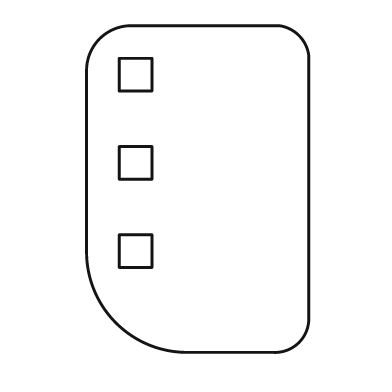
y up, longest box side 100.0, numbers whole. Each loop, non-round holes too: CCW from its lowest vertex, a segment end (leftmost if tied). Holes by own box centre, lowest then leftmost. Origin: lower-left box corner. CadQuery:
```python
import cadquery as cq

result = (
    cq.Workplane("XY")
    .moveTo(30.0, 0.0)
    .lineTo(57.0, 0.0)
    .threePointArc((65.0, 3.0), (68.0, 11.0))
    .lineTo(68.0, 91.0)
    .threePointArc((65.0, 97.0), (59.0, 100.0))
    .lineTo(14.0, 100.0)
    .threePointArc((4.0, 96.0), (0.0, 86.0))
    .lineTo(0.0, 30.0)
    .threePointArc((9.0, 9.0), (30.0, 0.0))
    .close()
    .moveTo(10.0, 26.0)
    .lineTo(20.0, 26.0)
    .lineTo(20.0, 36.0)
    .lineTo(10.0, 36.0)
    .close()
    .moveTo(10.0, 53.0)
    .lineTo(20.0, 53.0)
    .lineTo(20.0, 63.0)
    .lineTo(10.0, 63.0)
    .close()
    .moveTo(10.0, 80.0)
    .lineTo(20.0, 80.0)
    .lineTo(20.0, 90.0)
    .lineTo(10.0, 90.0)
    .close()
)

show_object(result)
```